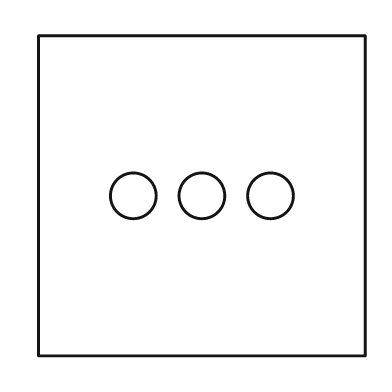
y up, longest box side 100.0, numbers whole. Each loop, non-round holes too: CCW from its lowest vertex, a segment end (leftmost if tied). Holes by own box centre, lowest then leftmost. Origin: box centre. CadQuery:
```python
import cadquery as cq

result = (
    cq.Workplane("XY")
    .moveTo(-50.0, -49.0)
    .lineTo(50.0, -49.0)
    .lineTo(50.0, 49.0)
    .lineTo(-50.0, 49.0)
    .close()
    .moveTo(-21.0, 0.0)
    .circle(7.0)
    .moveTo(0.0, 0.0)
    .circle(7.0)
    .moveTo(21.0, 0.0)
    .circle(7.0)
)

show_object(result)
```